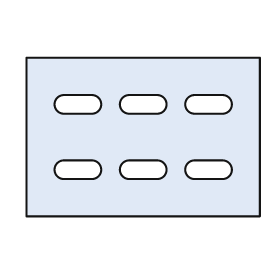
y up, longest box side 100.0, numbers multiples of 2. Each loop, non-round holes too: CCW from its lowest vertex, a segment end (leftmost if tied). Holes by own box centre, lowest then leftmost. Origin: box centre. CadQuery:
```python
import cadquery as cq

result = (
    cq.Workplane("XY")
    .moveTo(-50.0, -34.0)
    .lineTo(50.0, -34.0)
    .lineTo(50.0, 34.0)
    .lineTo(-50.0, 34.0)
    .close()
    .moveTo(-34.0, -18.0)
    .lineTo(-22.0, -18.0)
    .threePointArc((-18.0, -14.0), (-22.0, -10.0))
    .lineTo(-34.0, -10.0)
    .threePointArc((-38.0, -14.0), (-34.0, -18.0))
    .close()
    .moveTo(-6.0, -18.0)
    .lineTo(6.0, -18.0)
    .threePointArc((10.0, -14.0), (6.0, -10.0))
    .lineTo(-6.0, -10.0)
    .threePointArc((-10.0, -14.0), (-6.0, -18.0))
    .close()
    .moveTo(22.0, -18.0)
    .lineTo(34.0, -18.0)
    .threePointArc((38.0, -14.0), (34.0, -10.0))
    .lineTo(22.0, -10.0)
    .threePointArc((18.0, -14.0), (22.0, -18.0))
    .close()
    .moveTo(-34.0, 10.0)
    .lineTo(-22.0, 10.0)
    .threePointArc((-18.0, 14.0), (-22.0, 18.0))
    .lineTo(-34.0, 18.0)
    .threePointArc((-38.0, 14.0), (-34.0, 10.0))
    .close()
    .moveTo(-6.0, 10.0)
    .lineTo(6.0, 10.0)
    .threePointArc((10.0, 14.0), (6.0, 18.0))
    .lineTo(-6.0, 18.0)
    .threePointArc((-10.0, 14.0), (-6.0, 10.0))
    .close()
    .moveTo(22.0, 10.0)
    .lineTo(34.0, 10.0)
    .threePointArc((38.0, 14.0), (34.0, 18.0))
    .lineTo(22.0, 18.0)
    .threePointArc((18.0, 14.0), (22.0, 10.0))
    .close()
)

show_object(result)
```